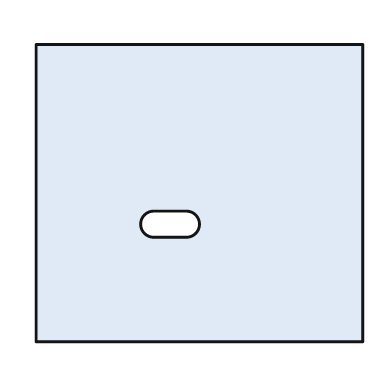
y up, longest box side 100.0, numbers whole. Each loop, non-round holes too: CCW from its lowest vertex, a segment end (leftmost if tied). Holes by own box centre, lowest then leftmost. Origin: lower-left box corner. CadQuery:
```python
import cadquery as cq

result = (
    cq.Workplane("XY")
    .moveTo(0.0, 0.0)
    .lineTo(100.0, 0.0)
    .lineTo(100.0, 91.0)
    .lineTo(0.0, 91.0)
    .close()
    .moveTo(36.0, 32.0)
    .lineTo(46.0, 32.0)
    .threePointArc((50.0, 36.0), (46.0, 40.0))
    .lineTo(36.0, 40.0)
    .threePointArc((32.0, 36.0), (36.0, 32.0))
    .close()
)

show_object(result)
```